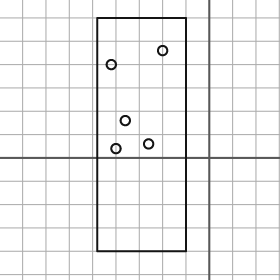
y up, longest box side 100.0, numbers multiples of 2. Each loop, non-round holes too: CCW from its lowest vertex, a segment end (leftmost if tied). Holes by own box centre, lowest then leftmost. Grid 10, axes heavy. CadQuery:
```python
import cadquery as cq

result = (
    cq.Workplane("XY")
    .moveTo(-48.0, -40.0)
    .lineTo(-10.0, -40.0)
    .lineTo(-10.0, 60.0)
    .lineTo(-48.0, 60.0)
    .close()
    .moveTo(-40.0, 4.0)
    .circle(2.0)
    .moveTo(-26.0, 6.0)
    .circle(2.0)
    .moveTo(-36.0, 16.0)
    .circle(2.0)
    .moveTo(-42.0, 40.0)
    .circle(2.0)
    .moveTo(-20.0, 46.0)
    .circle(2.0)
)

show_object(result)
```